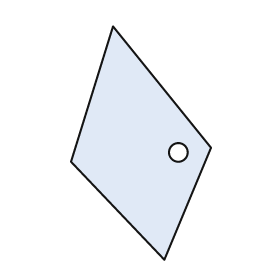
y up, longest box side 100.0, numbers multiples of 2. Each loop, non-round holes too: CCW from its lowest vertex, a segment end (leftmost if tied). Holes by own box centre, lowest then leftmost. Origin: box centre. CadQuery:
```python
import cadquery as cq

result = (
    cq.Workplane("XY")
    .moveTo(10.0, -50.0)
    .lineTo(30.0, -2.0)
    .lineTo(-12.0, 50.0)
    .lineTo(-30.0, -8.0)
    .close()
    .moveTo(16.0, -4.0)
    .circle(4.0)
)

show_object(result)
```